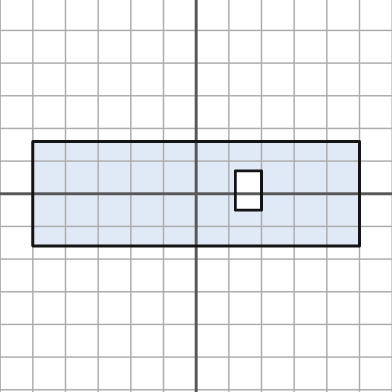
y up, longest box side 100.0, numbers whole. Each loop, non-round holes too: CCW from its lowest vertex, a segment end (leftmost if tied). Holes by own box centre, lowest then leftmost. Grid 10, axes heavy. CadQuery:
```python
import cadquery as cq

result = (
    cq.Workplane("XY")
    .moveTo(-50.0, -16.0)
    .lineTo(50.0, -16.0)
    .lineTo(50.0, 16.0)
    .lineTo(-50.0, 16.0)
    .close()
    .moveTo(12.0, -5.0)
    .lineTo(20.0, -5.0)
    .lineTo(20.0, 7.0)
    .lineTo(12.0, 7.0)
    .close()
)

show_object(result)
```